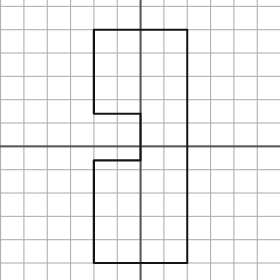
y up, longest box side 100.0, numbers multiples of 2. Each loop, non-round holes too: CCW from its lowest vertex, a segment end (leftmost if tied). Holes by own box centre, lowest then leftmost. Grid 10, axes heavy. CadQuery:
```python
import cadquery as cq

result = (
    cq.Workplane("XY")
    .moveTo(-20.0, -50.0)
    .lineTo(20.0, -50.0)
    .lineTo(20.0, 50.0)
    .lineTo(-20.0, 50.0)
    .lineTo(-20.0, 14.0)
    .lineTo(0.0, 14.0)
    .lineTo(0.0, -6.0)
    .lineTo(-20.0, -6.0)
    .close()
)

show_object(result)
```